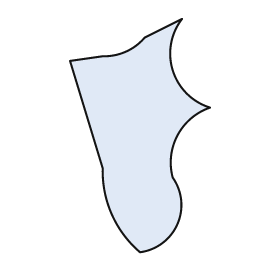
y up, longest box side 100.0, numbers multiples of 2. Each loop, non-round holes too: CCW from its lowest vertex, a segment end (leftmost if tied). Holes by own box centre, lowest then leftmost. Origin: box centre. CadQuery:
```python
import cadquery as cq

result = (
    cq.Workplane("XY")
    .moveTo(0.0, -50.0)
    .threePointArc((16.0, -38.0), (14.0, -18.0))
    .threePointArc((16.0, 0.0), (30.0, 12.0))
    .threePointArc((14.0, 28.0), (18.0, 50.0))
    .lineTo(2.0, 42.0)
    .threePointArc((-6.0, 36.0), (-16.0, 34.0))
    .lineTo(-30.0, 32.0)
    .lineTo(-16.0, -14.0)
    .threePointArc((-12.0, -34.0), (0.0, -50.0))
    .close()
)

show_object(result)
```